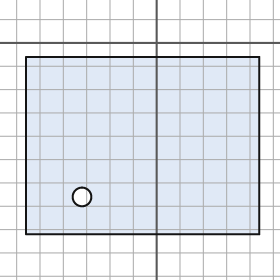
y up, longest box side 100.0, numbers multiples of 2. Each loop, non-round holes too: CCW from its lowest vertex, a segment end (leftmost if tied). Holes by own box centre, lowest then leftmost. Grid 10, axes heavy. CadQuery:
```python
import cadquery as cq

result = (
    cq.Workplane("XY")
    .moveTo(-56.0, -82.0)
    .lineTo(44.0, -82.0)
    .lineTo(44.0, -6.0)
    .lineTo(-56.0, -6.0)
    .close()
    .moveTo(-32.0, -66.0)
    .circle(4.0)
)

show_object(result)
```